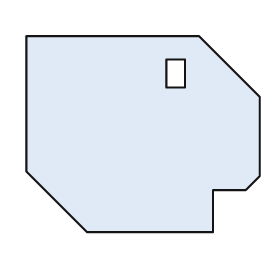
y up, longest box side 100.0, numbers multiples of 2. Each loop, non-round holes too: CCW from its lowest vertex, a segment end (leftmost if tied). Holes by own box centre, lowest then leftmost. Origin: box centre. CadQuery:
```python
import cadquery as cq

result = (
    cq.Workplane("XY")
    .moveTo(-24.0, -42.0)
    .lineTo(30.0, -42.0)
    .lineTo(30.0, -24.0)
    .lineTo(44.0, -24.0)
    .lineTo(50.0, -18.0)
    .lineTo(50.0, 16.0)
    .lineTo(24.0, 42.0)
    .lineTo(-50.0, 42.0)
    .lineTo(-50.0, -16.0)
    .close()
    .moveTo(10.0, 20.0)
    .lineTo(18.0, 20.0)
    .lineTo(18.0, 32.0)
    .lineTo(10.0, 32.0)
    .close()
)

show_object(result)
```